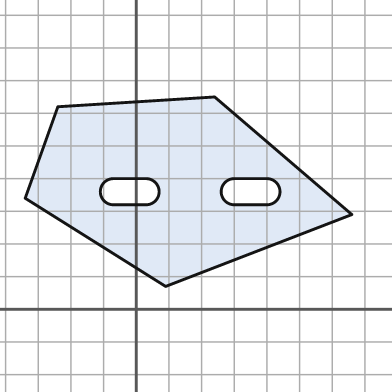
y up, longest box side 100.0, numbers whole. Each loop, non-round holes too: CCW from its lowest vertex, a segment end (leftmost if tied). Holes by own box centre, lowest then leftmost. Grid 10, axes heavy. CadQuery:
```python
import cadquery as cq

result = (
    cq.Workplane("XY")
    .moveTo(9.0, 7.0)
    .lineTo(66.0, 29.0)
    .lineTo(24.0, 65.0)
    .lineTo(-24.0, 62.0)
    .lineTo(-34.0, 34.0)
    .close()
    .moveTo(-7.0, 32.0)
    .lineTo(3.0, 32.0)
    .threePointArc((7.0, 36.0), (3.0, 40.0))
    .lineTo(-7.0, 40.0)
    .threePointArc((-11.0, 36.0), (-7.0, 32.0))
    .close()
    .moveTo(30.0, 32.0)
    .lineTo(40.0, 32.0)
    .threePointArc((44.0, 36.0), (40.0, 40.0))
    .lineTo(30.0, 40.0)
    .threePointArc((26.0, 36.0), (30.0, 32.0))
    .close()
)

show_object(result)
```